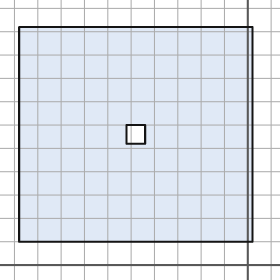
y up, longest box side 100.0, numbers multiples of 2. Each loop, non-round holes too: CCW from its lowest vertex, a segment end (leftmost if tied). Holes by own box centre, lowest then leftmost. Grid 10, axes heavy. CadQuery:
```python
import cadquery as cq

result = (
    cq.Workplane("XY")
    .moveTo(-98.0, 10.0)
    .lineTo(2.0, 10.0)
    .lineTo(2.0, 102.0)
    .lineTo(-98.0, 102.0)
    .close()
    .moveTo(-52.0, 52.0)
    .lineTo(-44.0, 52.0)
    .lineTo(-44.0, 60.0)
    .lineTo(-52.0, 60.0)
    .close()
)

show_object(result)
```